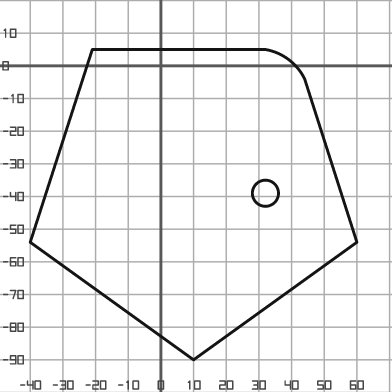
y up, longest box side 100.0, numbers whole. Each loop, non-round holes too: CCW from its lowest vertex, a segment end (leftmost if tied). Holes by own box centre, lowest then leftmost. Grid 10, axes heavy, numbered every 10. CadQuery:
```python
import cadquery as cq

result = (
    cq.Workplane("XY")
    .moveTo(10.0, -90.0)
    .lineTo(60.0, -54.0)
    .lineTo(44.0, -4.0)
    .threePointArc((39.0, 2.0), (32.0, 5.0))
    .lineTo(-21.0, 5.0)
    .lineTo(-40.0, -54.0)
    .close()
    .moveTo(32.0, -39.0)
    .circle(4.0)
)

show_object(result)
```